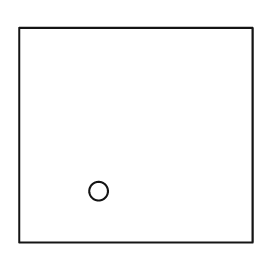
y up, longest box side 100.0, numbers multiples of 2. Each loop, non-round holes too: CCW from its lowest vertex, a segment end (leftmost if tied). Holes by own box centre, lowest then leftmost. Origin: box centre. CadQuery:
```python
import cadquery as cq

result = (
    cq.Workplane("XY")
    .moveTo(-50.0, -46.0)
    .lineTo(50.0, -46.0)
    .lineTo(50.0, 46.0)
    .lineTo(-50.0, 46.0)
    .close()
    .moveTo(-16.0, -24.0)
    .circle(4.0)
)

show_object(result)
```